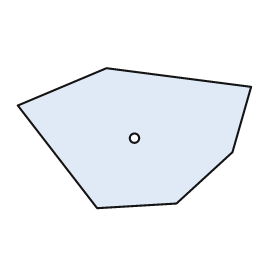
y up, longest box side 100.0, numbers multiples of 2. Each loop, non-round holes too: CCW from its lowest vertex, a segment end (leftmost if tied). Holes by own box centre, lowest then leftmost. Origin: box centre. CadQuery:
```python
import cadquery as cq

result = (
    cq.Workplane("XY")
    .moveTo(-16.0, -30.0)
    .lineTo(18.0, -28.0)
    .lineTo(42.0, -6.0)
    .lineTo(50.0, 22.0)
    .lineTo(-12.0, 30.0)
    .lineTo(-50.0, 14.0)
    .close()
    .moveTo(0.0, 0.0)
    .circle(2.0)
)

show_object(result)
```